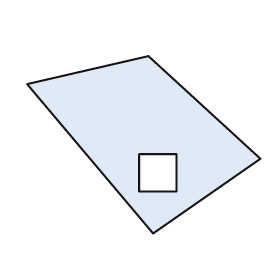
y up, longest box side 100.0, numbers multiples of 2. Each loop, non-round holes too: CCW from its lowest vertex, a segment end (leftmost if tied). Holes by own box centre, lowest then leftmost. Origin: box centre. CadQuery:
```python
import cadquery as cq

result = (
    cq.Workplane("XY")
    .moveTo(4.0, -38.0)
    .lineTo(50.0, -6.0)
    .lineTo(2.0, 38.0)
    .lineTo(-50.0, 26.0)
    .close()
    .moveTo(-2.0, -20.0)
    .lineTo(14.0, -20.0)
    .lineTo(14.0, -4.0)
    .lineTo(-2.0, -4.0)
    .close()
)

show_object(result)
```